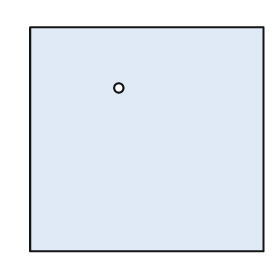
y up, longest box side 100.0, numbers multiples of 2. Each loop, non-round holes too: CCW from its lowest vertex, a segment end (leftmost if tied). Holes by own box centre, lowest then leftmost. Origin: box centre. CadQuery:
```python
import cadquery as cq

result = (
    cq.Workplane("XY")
    .moveTo(-50.0, -48.0)
    .lineTo(50.0, -48.0)
    .lineTo(50.0, 48.0)
    .lineTo(-50.0, 48.0)
    .close()
    .moveTo(-12.0, 22.0)
    .circle(2.0)
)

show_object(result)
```